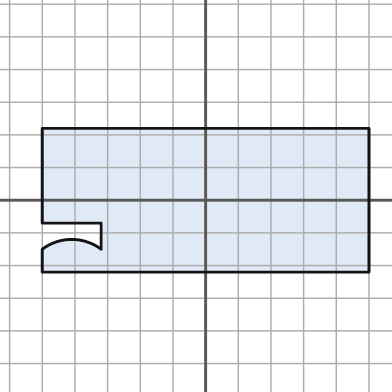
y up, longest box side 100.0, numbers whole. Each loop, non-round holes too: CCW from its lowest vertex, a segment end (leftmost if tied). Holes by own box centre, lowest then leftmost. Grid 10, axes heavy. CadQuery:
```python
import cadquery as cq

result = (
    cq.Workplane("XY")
    .moveTo(-50.0, -22.0)
    .lineTo(50.0, -22.0)
    .lineTo(50.0, 22.0)
    .lineTo(-50.0, 22.0)
    .lineTo(-50.0, -7.0)
    .lineTo(-32.0, -7.0)
    .lineTo(-32.0, -15.0)
    .threePointArc((-41.0, -12.0), (-50.0, -15.0))
    .close()
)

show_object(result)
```